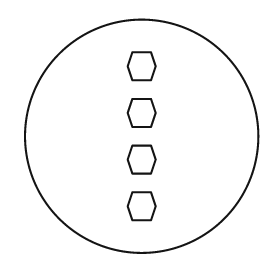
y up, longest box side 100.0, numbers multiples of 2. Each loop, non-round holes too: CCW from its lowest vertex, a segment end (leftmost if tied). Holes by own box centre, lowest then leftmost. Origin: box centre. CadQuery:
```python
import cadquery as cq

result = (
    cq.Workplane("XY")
    .moveTo(0.0, 0.0)
    .circle(50.0)
    .moveTo(-4.0, -36.0)
    .lineTo(4.0, -36.0)
    .lineTo(6.0, -30.0)
    .lineTo(4.0, -24.0)
    .lineTo(-4.0, -24.0)
    .lineTo(-6.0, -30.0)
    .close()
    .moveTo(-4.0, -16.0)
    .lineTo(4.0, -16.0)
    .lineTo(6.0, -10.0)
    .lineTo(4.0, -4.0)
    .lineTo(-4.0, -4.0)
    .lineTo(-6.0, -10.0)
    .close()
    .moveTo(-4.0, 4.0)
    .lineTo(4.0, 4.0)
    .lineTo(6.0, 10.0)
    .lineTo(4.0, 16.0)
    .lineTo(-4.0, 16.0)
    .lineTo(-6.0, 10.0)
    .close()
    .moveTo(-4.0, 24.0)
    .lineTo(4.0, 24.0)
    .lineTo(6.0, 30.0)
    .lineTo(4.0, 36.0)
    .lineTo(-4.0, 36.0)
    .lineTo(-6.0, 30.0)
    .close()
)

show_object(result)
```